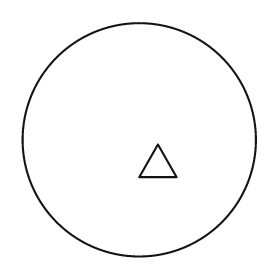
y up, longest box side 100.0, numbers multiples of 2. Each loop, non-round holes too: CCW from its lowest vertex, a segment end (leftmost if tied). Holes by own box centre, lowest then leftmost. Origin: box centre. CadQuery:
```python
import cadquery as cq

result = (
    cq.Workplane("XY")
    .moveTo(0.0, 0.0)
    .circle(50.0)
    .moveTo(0.0, -16.0)
    .lineTo(16.0, -16.0)
    .lineTo(8.0, -2.0)
    .close()
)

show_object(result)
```